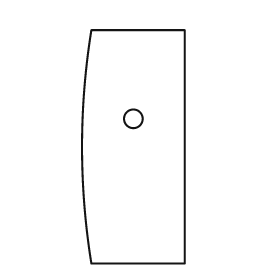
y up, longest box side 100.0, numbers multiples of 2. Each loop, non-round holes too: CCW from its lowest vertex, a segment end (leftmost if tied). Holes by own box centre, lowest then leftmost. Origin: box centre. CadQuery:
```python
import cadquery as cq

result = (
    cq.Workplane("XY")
    .moveTo(-18.0, -50.0)
    .lineTo(22.0, -50.0)
    .lineTo(22.0, 50.0)
    .lineTo(-18.0, 50.0)
    .threePointArc((-22.0, 0.0), (-18.0, -50.0))
    .close()
    .moveTo(0.0, 12.0)
    .circle(4.0)
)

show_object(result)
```